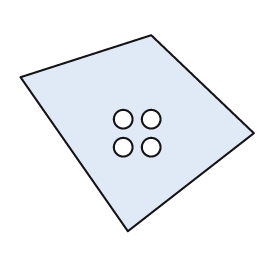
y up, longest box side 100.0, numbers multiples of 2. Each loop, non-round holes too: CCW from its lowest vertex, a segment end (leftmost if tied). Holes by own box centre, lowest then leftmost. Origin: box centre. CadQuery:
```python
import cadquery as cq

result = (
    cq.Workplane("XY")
    .moveTo(-4.0, -42.0)
    .lineTo(50.0, 0.0)
    .lineTo(6.0, 42.0)
    .lineTo(-50.0, 24.0)
    .close()
    .moveTo(-6.0, -6.0)
    .circle(4.0)
    .moveTo(6.0, -6.0)
    .circle(4.0)
    .moveTo(-6.0, 6.0)
    .circle(4.0)
    .moveTo(6.0, 6.0)
    .circle(4.0)
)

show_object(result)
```